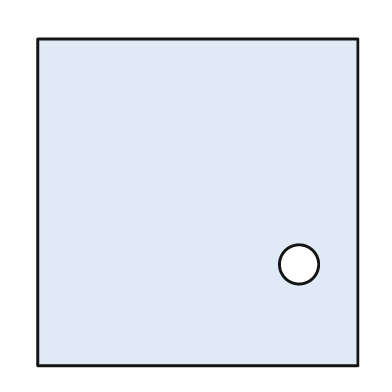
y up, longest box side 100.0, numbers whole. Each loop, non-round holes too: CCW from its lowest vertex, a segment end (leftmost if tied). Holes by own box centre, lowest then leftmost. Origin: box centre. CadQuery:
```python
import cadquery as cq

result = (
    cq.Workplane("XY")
    .moveTo(-49.0, -50.0)
    .lineTo(49.0, -50.0)
    .lineTo(49.0, 50.0)
    .lineTo(-49.0, 50.0)
    .close()
    .moveTo(31.0, -19.0)
    .circle(6.0)
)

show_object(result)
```